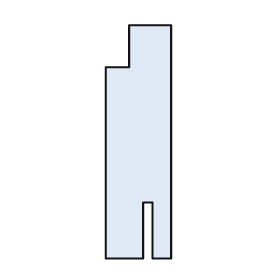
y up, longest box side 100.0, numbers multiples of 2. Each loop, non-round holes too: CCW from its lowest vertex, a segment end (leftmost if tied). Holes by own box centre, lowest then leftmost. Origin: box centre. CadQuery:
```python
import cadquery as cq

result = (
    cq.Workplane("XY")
    .moveTo(-14.0, -50.0)
    .lineTo(2.0, -50.0)
    .lineTo(2.0, -26.0)
    .lineTo(6.0, -26.0)
    .lineTo(6.0, -50.0)
    .lineTo(14.0, -50.0)
    .lineTo(14.0, 50.0)
    .lineTo(-4.0, 50.0)
    .lineTo(-4.0, 32.0)
    .lineTo(-14.0, 32.0)
    .close()
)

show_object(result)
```